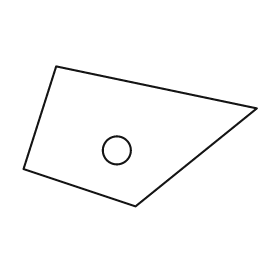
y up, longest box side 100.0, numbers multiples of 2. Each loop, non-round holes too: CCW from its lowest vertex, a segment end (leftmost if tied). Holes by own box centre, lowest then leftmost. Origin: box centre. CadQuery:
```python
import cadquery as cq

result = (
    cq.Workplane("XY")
    .moveTo(-2.0, -30.0)
    .lineTo(50.0, 12.0)
    .lineTo(-36.0, 30.0)
    .lineTo(-50.0, -14.0)
    .close()
    .moveTo(-10.0, -6.0)
    .circle(6.0)
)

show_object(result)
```